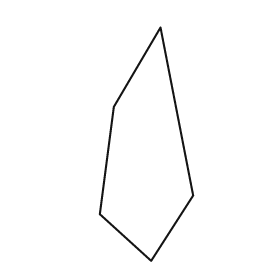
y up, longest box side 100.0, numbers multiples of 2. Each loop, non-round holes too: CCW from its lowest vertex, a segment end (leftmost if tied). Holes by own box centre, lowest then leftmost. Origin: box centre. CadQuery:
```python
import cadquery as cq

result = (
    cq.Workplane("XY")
    .moveTo(2.0, -50.0)
    .lineTo(20.0, -22.0)
    .lineTo(6.0, 50.0)
    .lineTo(-14.0, 16.0)
    .lineTo(-20.0, -30.0)
    .close()
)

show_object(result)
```